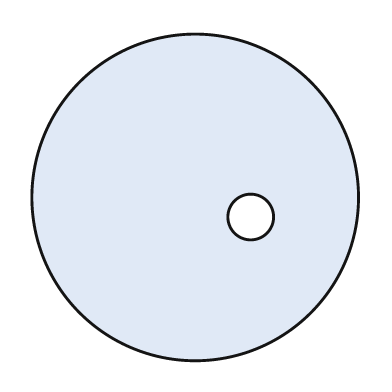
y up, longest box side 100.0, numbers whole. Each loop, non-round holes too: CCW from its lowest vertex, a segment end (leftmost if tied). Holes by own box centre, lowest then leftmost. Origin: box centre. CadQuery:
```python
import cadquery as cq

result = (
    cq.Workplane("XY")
    .moveTo(0.0, 0.0)
    .circle(50.0)
    .moveTo(17.0, -6.0)
    .circle(7.0)
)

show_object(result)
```